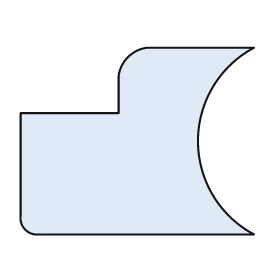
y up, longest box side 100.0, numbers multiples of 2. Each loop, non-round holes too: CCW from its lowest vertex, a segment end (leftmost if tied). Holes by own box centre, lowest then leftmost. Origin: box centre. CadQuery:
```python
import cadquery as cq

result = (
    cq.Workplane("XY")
    .moveTo(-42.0, -40.0)
    .lineTo(50.0, -40.0)
    .threePointArc((26.0, 0.0), (50.0, 40.0))
    .lineTo(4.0, 40.0)
    .threePointArc((-4.0, 36.0), (-8.0, 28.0))
    .lineTo(-8.0, 12.0)
    .lineTo(-50.0, 12.0)
    .lineTo(-50.0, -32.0)
    .threePointArc((-48.0, -38.0), (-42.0, -40.0))
    .close()
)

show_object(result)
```